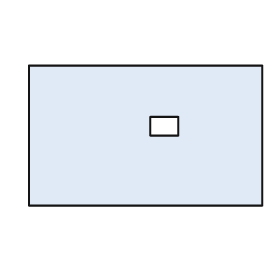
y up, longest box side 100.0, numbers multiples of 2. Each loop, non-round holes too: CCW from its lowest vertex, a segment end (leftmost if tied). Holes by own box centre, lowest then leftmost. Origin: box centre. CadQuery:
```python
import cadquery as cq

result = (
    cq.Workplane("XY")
    .moveTo(-50.0, -30.0)
    .lineTo(50.0, -30.0)
    .lineTo(50.0, 30.0)
    .lineTo(-50.0, 30.0)
    .close()
    .moveTo(2.0, 0.0)
    .lineTo(14.0, 0.0)
    .lineTo(14.0, 8.0)
    .lineTo(2.0, 8.0)
    .close()
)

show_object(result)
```